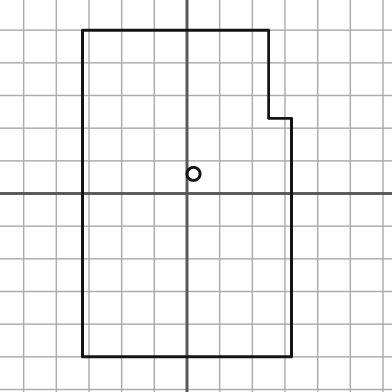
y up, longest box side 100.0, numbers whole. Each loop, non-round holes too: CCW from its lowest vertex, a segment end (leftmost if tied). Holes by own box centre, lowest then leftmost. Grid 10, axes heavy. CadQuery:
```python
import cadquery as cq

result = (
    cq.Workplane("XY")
    .moveTo(-32.0, -50.0)
    .lineTo(32.0, -50.0)
    .lineTo(32.0, 23.0)
    .lineTo(25.0, 23.0)
    .lineTo(25.0, 50.0)
    .lineTo(-32.0, 50.0)
    .close()
    .moveTo(2.0, 6.0)
    .circle(2.0)
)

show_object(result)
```